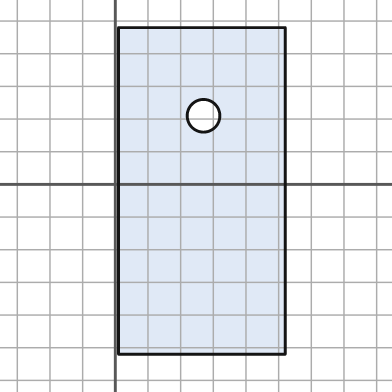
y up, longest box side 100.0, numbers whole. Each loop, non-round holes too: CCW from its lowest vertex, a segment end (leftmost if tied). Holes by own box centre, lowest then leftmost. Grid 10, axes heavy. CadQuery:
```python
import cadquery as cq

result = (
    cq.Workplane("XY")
    .moveTo(1.0, -52.0)
    .lineTo(52.0, -52.0)
    .lineTo(52.0, 48.0)
    .lineTo(1.0, 48.0)
    .close()
    .moveTo(27.0, 21.0)
    .circle(5.0)
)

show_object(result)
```